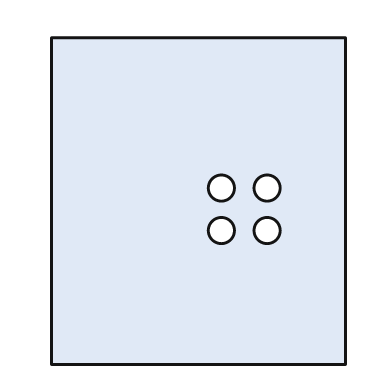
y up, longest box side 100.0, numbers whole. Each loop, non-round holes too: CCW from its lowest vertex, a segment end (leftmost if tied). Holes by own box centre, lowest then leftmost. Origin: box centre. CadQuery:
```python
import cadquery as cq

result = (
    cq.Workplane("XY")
    .moveTo(-45.0, -50.0)
    .lineTo(45.0, -50.0)
    .lineTo(45.0, 50.0)
    .lineTo(-45.0, 50.0)
    .close()
    .moveTo(7.0, -9.0)
    .circle(4.0)
    .moveTo(21.0, -9.0)
    .circle(4.0)
    .moveTo(7.0, 4.0)
    .circle(4.0)
    .moveTo(21.0, 4.0)
    .circle(4.0)
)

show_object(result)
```